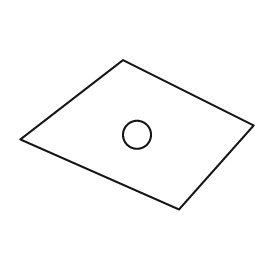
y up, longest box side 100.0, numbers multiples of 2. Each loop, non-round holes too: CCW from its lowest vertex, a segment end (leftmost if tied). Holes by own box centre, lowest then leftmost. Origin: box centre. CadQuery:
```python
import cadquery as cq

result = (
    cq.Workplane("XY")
    .moveTo(18.0, -32.0)
    .lineTo(50.0, 4.0)
    .lineTo(-6.0, 32.0)
    .lineTo(-50.0, -2.0)
    .close()
    .moveTo(0.0, 0.0)
    .circle(6.0)
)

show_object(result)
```